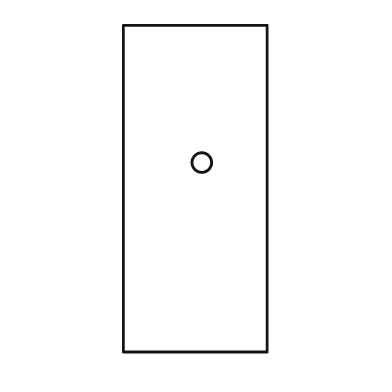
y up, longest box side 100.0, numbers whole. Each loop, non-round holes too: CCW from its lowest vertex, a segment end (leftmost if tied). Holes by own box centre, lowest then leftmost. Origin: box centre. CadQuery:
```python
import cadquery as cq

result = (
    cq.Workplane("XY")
    .moveTo(-22.0, -50.0)
    .lineTo(22.0, -50.0)
    .lineTo(22.0, 50.0)
    .lineTo(-22.0, 50.0)
    .close()
    .moveTo(2.0, 8.0)
    .circle(3.0)
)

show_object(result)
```